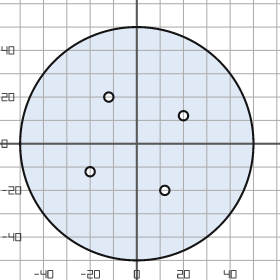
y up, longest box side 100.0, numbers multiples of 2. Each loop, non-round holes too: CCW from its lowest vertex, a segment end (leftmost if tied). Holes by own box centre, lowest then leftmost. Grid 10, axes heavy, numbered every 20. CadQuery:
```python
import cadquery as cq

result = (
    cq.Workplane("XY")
    .moveTo(0.0, 0.0)
    .circle(50.0)
    .moveTo(12.0, -20.0)
    .circle(2.0)
    .moveTo(-20.0, -12.0)
    .circle(2.0)
    .moveTo(20.0, 12.0)
    .circle(2.0)
    .moveTo(-12.0, 20.0)
    .circle(2.0)
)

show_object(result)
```